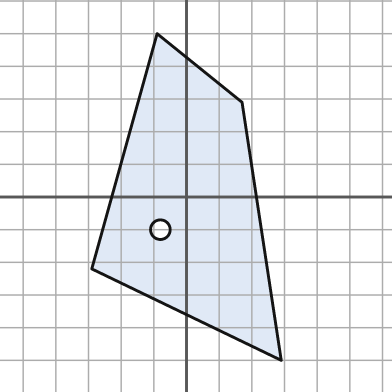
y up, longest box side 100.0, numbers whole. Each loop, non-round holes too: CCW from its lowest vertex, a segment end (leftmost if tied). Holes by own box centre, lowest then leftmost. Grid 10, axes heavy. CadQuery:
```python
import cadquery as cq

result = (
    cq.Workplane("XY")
    .moveTo(29.0, -50.0)
    .lineTo(17.0, 29.0)
    .lineTo(-9.0, 50.0)
    .lineTo(-29.0, -22.0)
    .close()
    .moveTo(-8.0, -10.0)
    .circle(3.0)
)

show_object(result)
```